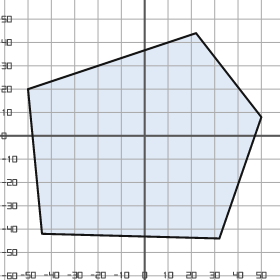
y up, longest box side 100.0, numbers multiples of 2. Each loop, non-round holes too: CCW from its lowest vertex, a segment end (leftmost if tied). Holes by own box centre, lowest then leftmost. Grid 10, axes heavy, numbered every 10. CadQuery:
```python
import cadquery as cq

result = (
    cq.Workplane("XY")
    .moveTo(32.0, -44.0)
    .lineTo(50.0, 8.0)
    .lineTo(22.0, 44.0)
    .lineTo(-50.0, 20.0)
    .lineTo(-44.0, -42.0)
    .close()
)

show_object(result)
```